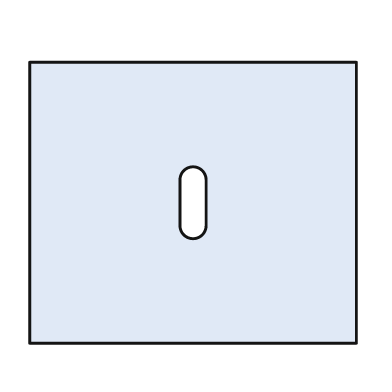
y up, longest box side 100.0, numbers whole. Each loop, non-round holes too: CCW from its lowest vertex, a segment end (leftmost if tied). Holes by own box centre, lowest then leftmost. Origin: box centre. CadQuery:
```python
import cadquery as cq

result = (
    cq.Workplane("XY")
    .moveTo(-50.0, -43.0)
    .lineTo(50.0, -43.0)
    .lineTo(50.0, 43.0)
    .lineTo(-50.0, 43.0)
    .close()
    .moveTo(-4.0, -7.0)
    .threePointArc((0.0, -11.0), (4.0, -7.0))
    .lineTo(4.0, 7.0)
    .threePointArc((0.0, 11.0), (-4.0, 7.0))
    .close()
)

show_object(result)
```